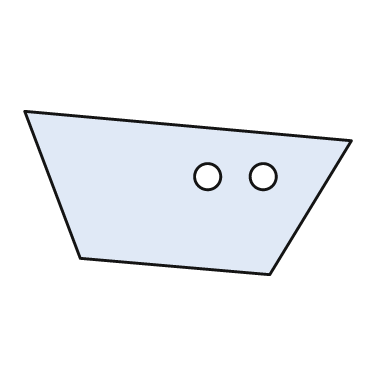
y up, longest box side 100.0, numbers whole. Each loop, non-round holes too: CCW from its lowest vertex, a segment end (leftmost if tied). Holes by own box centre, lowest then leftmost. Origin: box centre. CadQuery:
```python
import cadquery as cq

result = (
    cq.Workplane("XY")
    .moveTo(25.0, -25.0)
    .lineTo(50.0, 16.0)
    .lineTo(-50.0, 25.0)
    .lineTo(-33.0, -20.0)
    .close()
    .moveTo(6.0, 5.0)
    .circle(4.0)
    .moveTo(23.0, 5.0)
    .circle(4.0)
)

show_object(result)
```